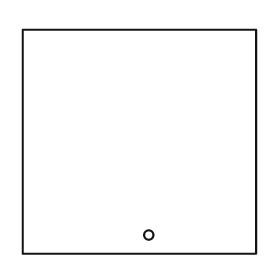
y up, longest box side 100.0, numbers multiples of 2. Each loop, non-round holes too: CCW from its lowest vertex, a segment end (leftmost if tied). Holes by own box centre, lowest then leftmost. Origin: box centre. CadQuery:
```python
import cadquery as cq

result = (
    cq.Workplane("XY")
    .moveTo(-50.0, -48.0)
    .lineTo(50.0, -48.0)
    .lineTo(50.0, 48.0)
    .lineTo(-50.0, 48.0)
    .close()
    .moveTo(4.0, -40.0)
    .circle(2.0)
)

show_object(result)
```